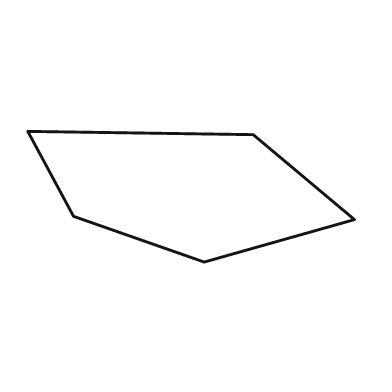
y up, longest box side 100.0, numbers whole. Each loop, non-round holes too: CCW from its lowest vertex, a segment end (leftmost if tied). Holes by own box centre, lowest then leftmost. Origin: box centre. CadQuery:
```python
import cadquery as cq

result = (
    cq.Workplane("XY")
    .moveTo(4.0, -20.0)
    .lineTo(50.0, -7.0)
    .lineTo(19.0, 19.0)
    .lineTo(-50.0, 20.0)
    .lineTo(-36.0, -6.0)
    .close()
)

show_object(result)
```